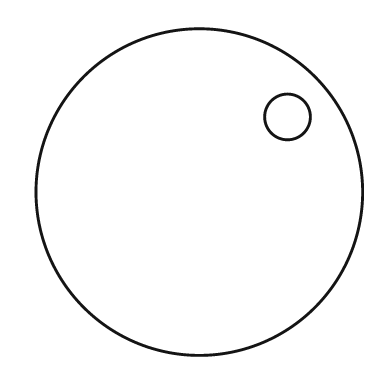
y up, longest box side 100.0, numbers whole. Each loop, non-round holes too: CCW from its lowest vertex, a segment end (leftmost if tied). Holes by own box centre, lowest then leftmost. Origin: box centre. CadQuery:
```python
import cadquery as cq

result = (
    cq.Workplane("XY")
    .moveTo(0.0, 0.0)
    .circle(50.0)
    .moveTo(27.0, 23.0)
    .circle(7.0)
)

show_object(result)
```